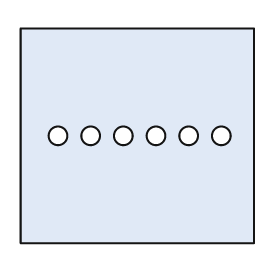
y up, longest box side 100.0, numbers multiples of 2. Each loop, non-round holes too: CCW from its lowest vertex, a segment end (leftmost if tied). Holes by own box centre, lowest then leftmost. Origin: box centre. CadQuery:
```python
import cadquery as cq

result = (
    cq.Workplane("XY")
    .moveTo(-50.0, -46.0)
    .lineTo(50.0, -46.0)
    .lineTo(50.0, 46.0)
    .lineTo(-50.0, 46.0)
    .close()
    .moveTo(-34.0, 0.0)
    .circle(4.0)
    .moveTo(-20.0, 0.0)
    .circle(4.0)
    .moveTo(-6.0, 0.0)
    .circle(4.0)
    .moveTo(8.0, 0.0)
    .circle(4.0)
    .moveTo(22.0, 0.0)
    .circle(4.0)
    .moveTo(36.0, 0.0)
    .circle(4.0)
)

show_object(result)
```